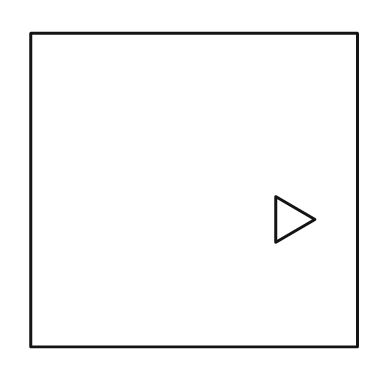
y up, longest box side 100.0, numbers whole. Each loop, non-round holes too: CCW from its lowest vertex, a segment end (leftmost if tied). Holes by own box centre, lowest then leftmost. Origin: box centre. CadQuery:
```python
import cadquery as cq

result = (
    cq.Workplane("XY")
    .moveTo(-50.0, -48.0)
    .lineTo(50.0, -48.0)
    .lineTo(50.0, 48.0)
    .lineTo(-50.0, 48.0)
    .close()
    .moveTo(25.0, -16.0)
    .lineTo(37.0, -9.0)
    .lineTo(25.0, -2.0)
    .close()
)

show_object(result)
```